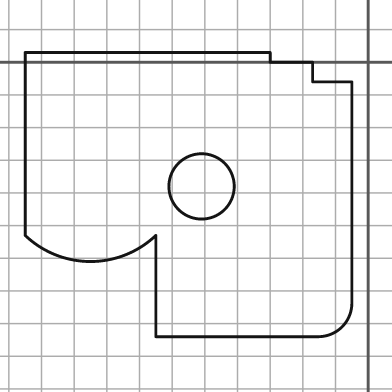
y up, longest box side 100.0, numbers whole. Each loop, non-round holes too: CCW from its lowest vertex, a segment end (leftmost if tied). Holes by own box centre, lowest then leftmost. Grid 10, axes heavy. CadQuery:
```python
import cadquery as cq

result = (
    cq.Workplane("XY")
    .moveTo(-65.0, -84.0)
    .lineTo(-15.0, -84.0)
    .threePointArc((-8.0, -81.0), (-5.0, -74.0))
    .lineTo(-5.0, -6.0)
    .lineTo(-17.0, -6.0)
    .lineTo(-17.0, 0.0)
    .lineTo(-30.0, 0.0)
    .lineTo(-30.0, 3.0)
    .lineTo(-105.0, 3.0)
    .lineTo(-105.0, -53.0)
    .threePointArc((-85.0, -61.0), (-65.0, -53.0))
    .close()
    .moveTo(-51.0, -38.0)
    .circle(10.0)
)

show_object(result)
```